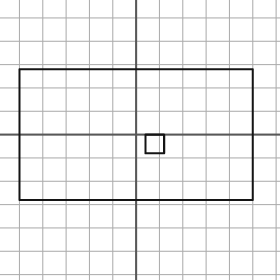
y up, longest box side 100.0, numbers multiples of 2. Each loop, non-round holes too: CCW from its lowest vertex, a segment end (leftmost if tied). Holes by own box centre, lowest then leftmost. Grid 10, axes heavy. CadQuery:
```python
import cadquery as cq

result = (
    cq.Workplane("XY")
    .moveTo(-50.0, -28.0)
    .lineTo(50.0, -28.0)
    .lineTo(50.0, 28.0)
    .lineTo(-50.0, 28.0)
    .close()
    .moveTo(4.0, -8.0)
    .lineTo(12.0, -8.0)
    .lineTo(12.0, 0.0)
    .lineTo(4.0, 0.0)
    .close()
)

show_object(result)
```